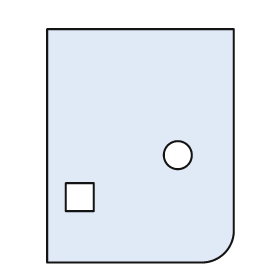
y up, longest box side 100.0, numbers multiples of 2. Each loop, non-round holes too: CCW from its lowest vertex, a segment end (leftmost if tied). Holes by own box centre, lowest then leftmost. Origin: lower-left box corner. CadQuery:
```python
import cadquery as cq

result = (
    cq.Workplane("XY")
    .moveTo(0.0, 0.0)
    .lineTo(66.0, 0.0)
    .threePointArc((76.0, 4.0), (80.0, 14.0))
    .lineTo(80.0, 100.0)
    .lineTo(0.0, 100.0)
    .close()
    .moveTo(8.0, 22.0)
    .lineTo(20.0, 22.0)
    .lineTo(20.0, 34.0)
    .lineTo(8.0, 34.0)
    .close()
    .moveTo(56.0, 46.0)
    .circle(6.0)
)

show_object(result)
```